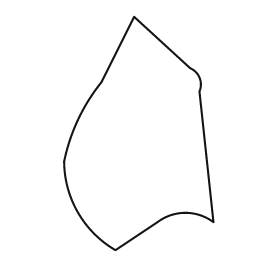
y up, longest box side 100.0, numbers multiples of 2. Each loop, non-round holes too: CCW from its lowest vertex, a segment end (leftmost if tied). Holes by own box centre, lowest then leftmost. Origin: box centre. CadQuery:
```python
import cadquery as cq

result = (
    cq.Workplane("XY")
    .moveTo(-10.0, -50.0)
    .lineTo(8.0, -38.0)
    .threePointArc((20.0, -34.0), (32.0, -38.0))
    .lineTo(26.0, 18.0)
    .threePointArc((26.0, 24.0), (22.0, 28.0))
    .lineTo(-2.0, 50.0)
    .lineTo(-16.0, 22.0)
    .threePointArc((-26.0, 6.0), (-32.0, -12.0))
    .threePointArc((-26.0, -34.0), (-10.0, -50.0))
    .close()
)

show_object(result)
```